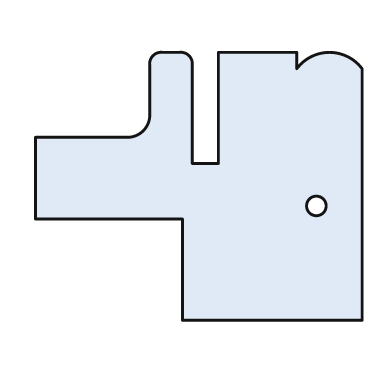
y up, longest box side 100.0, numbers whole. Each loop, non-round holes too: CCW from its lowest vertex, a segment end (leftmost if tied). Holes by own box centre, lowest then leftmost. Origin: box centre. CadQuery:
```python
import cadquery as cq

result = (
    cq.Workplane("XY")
    .moveTo(-5.0, -41.0)
    .lineTo(50.0, -41.0)
    .lineTo(50.0, 36.0)
    .threePointArc((40.0, 41.0), (30.0, 36.0))
    .lineTo(30.0, 41.0)
    .lineTo(6.0, 41.0)
    .lineTo(6.0, 7.0)
    .lineTo(-2.0, 7.0)
    .lineTo(-2.0, 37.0)
    .threePointArc((-3.0, 40.0), (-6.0, 41.0))
    .lineTo(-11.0, 41.0)
    .threePointArc((-14.0, 40.0), (-15.0, 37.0))
    .lineTo(-15.0, 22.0)
    .threePointArc((-17.0, 17.0), (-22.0, 15.0))
    .lineTo(-50.0, 15.0)
    .lineTo(-50.0, -10.0)
    .lineTo(-5.0, -10.0)
    .close()
    .moveTo(36.0, -6.0)
    .circle(3.0)
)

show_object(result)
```